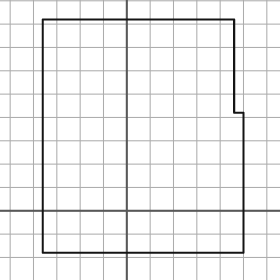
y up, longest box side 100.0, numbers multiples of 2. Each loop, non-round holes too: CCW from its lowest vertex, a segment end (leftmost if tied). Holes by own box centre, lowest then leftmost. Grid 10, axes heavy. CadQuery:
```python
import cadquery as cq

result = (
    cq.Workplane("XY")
    .moveTo(-36.0, -18.0)
    .lineTo(50.0, -18.0)
    .lineTo(50.0, 42.0)
    .lineTo(46.0, 42.0)
    .lineTo(46.0, 82.0)
    .lineTo(-36.0, 82.0)
    .close()
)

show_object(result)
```